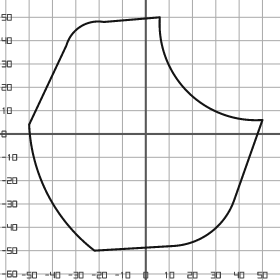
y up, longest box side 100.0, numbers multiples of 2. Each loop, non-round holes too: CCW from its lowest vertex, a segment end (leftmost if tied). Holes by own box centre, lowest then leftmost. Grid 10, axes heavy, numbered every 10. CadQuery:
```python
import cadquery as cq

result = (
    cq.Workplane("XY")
    .moveTo(-22.0, -50.0)
    .lineTo(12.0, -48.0)
    .threePointArc((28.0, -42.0), (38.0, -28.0))
    .lineTo(50.0, 6.0)
    .threePointArc((18.0, 18.0), (6.0, 50.0))
    .lineTo(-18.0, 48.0)
    .threePointArc((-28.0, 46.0), (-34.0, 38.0))
    .lineTo(-50.0, 4.0)
    .threePointArc((-42.0, -26.0), (-22.0, -50.0))
    .close()
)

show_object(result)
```